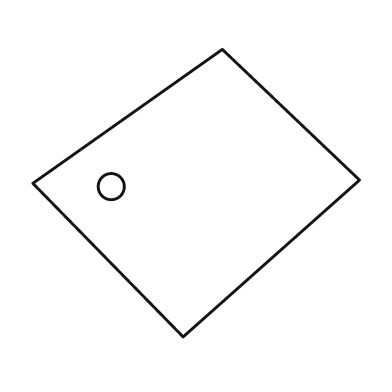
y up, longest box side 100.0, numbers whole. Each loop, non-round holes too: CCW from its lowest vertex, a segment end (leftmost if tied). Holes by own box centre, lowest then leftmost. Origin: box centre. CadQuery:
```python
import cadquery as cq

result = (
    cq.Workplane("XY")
    .moveTo(-4.0, -44.0)
    .lineTo(50.0, 4.0)
    .lineTo(8.0, 44.0)
    .lineTo(-50.0, 3.0)
    .close()
    .moveTo(-26.0, 2.0)
    .circle(4.0)
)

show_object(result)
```